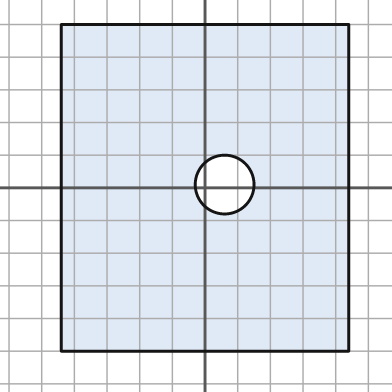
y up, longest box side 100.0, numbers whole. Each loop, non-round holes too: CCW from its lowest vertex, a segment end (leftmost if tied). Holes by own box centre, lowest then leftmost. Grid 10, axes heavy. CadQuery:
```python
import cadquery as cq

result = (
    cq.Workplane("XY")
    .moveTo(-44.0, -50.0)
    .lineTo(44.0, -50.0)
    .lineTo(44.0, 50.0)
    .lineTo(-44.0, 50.0)
    .close()
    .moveTo(6.0, 1.0)
    .circle(9.0)
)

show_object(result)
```